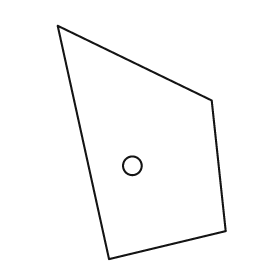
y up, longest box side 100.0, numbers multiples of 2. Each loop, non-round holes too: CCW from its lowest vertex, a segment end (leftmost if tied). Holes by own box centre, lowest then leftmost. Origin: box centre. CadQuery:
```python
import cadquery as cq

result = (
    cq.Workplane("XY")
    .moveTo(-14.0, -50.0)
    .lineTo(36.0, -38.0)
    .lineTo(30.0, 18.0)
    .lineTo(-36.0, 50.0)
    .close()
    .moveTo(-4.0, -10.0)
    .circle(4.0)
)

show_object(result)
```